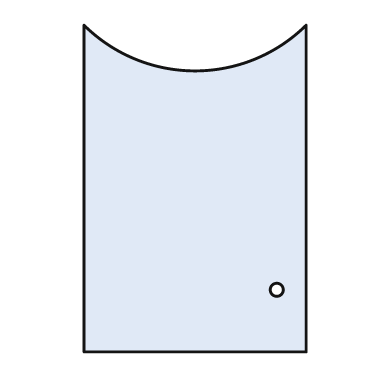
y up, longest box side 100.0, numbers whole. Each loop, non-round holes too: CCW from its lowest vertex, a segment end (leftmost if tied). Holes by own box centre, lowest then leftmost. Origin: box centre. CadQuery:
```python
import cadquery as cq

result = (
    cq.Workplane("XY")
    .moveTo(-34.0, -50.0)
    .lineTo(34.0, -50.0)
    .lineTo(34.0, 50.0)
    .threePointArc((0.0, 36.0), (-34.0, 50.0))
    .close()
    .moveTo(25.0, -31.0)
    .circle(2.0)
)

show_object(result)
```